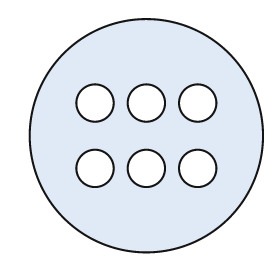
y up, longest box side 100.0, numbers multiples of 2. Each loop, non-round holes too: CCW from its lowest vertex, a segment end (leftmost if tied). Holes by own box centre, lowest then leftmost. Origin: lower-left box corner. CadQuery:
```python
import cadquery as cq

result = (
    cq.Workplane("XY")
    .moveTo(50.0, 50.0)
    .circle(50.0)
    .moveTo(28.0, 36.0)
    .circle(8.0)
    .moveTo(50.0, 36.0)
    .circle(8.0)
    .moveTo(72.0, 36.0)
    .circle(8.0)
    .moveTo(28.0, 64.0)
    .circle(8.0)
    .moveTo(50.0, 64.0)
    .circle(8.0)
    .moveTo(72.0, 64.0)
    .circle(8.0)
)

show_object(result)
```